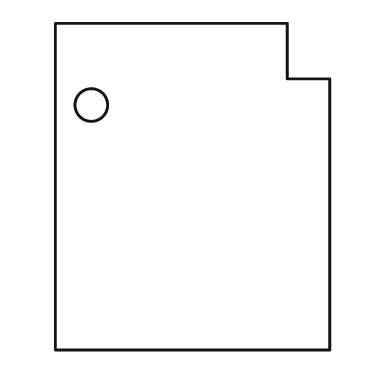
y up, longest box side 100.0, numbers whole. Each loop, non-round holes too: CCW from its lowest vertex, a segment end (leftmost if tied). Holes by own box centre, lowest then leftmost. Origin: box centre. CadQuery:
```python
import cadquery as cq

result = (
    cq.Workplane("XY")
    .moveTo(-42.0, -50.0)
    .lineTo(42.0, -50.0)
    .lineTo(42.0, 33.0)
    .lineTo(29.0, 33.0)
    .lineTo(29.0, 50.0)
    .lineTo(-42.0, 50.0)
    .close()
    .moveTo(-31.0, 25.0)
    .circle(5.0)
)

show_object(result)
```